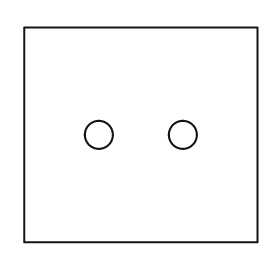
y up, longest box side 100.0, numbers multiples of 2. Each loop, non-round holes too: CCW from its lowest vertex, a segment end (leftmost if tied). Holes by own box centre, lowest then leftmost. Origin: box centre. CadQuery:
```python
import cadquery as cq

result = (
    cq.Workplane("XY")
    .moveTo(-50.0, -46.0)
    .lineTo(50.0, -46.0)
    .lineTo(50.0, 46.0)
    .lineTo(-50.0, 46.0)
    .close()
    .moveTo(-18.0, 0.0)
    .circle(6.0)
    .moveTo(18.0, 0.0)
    .circle(6.0)
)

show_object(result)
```